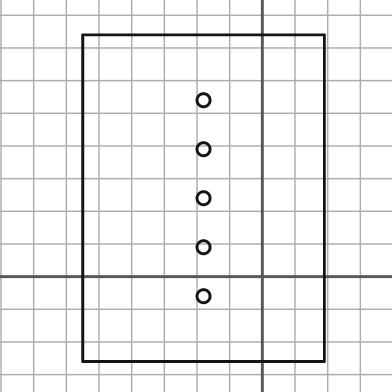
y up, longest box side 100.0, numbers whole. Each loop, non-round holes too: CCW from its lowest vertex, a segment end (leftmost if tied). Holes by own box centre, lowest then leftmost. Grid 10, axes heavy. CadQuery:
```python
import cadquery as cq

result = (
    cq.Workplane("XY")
    .moveTo(-55.0, -26.0)
    .lineTo(19.0, -26.0)
    .lineTo(19.0, 74.0)
    .lineTo(-55.0, 74.0)
    .close()
    .moveTo(-18.0, -6.0)
    .circle(2.0)
    .moveTo(-18.0, 9.0)
    .circle(2.0)
    .moveTo(-18.0, 24.0)
    .circle(2.0)
    .moveTo(-18.0, 39.0)
    .circle(2.0)
    .moveTo(-18.0, 54.0)
    .circle(2.0)
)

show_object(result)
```